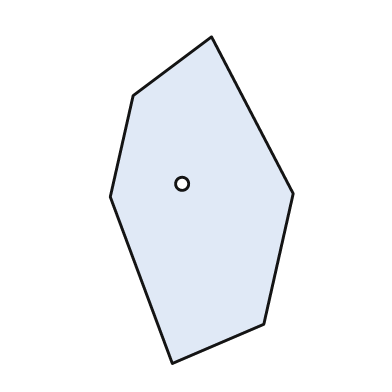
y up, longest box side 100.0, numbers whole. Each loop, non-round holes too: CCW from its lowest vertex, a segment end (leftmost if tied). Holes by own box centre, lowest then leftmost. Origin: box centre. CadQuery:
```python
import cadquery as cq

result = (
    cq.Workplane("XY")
    .moveTo(-9.0, -50.0)
    .lineTo(19.0, -38.0)
    .lineTo(28.0, 2.0)
    .lineTo(3.0, 50.0)
    .lineTo(-21.0, 32.0)
    .lineTo(-28.0, 1.0)
    .close()
    .moveTo(-6.0, 5.0)
    .circle(2.0)
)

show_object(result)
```